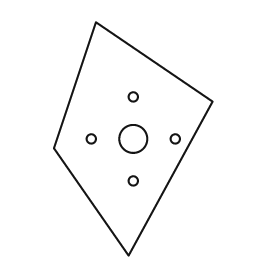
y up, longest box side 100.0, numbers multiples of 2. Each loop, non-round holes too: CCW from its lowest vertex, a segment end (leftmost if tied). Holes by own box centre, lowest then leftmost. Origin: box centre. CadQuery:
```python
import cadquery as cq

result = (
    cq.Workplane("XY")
    .moveTo(-2.0, -50.0)
    .lineTo(34.0, 16.0)
    .lineTo(-16.0, 50.0)
    .lineTo(-34.0, -4.0)
    .close()
    .moveTo(0.0, -18.0)
    .circle(2.0)
    .moveTo(-18.0, 0.0)
    .circle(2.0)
    .moveTo(0.0, 0.0)
    .circle(6.0)
    .moveTo(18.0, 0.0)
    .circle(2.0)
    .moveTo(0.0, 18.0)
    .circle(2.0)
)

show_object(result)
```